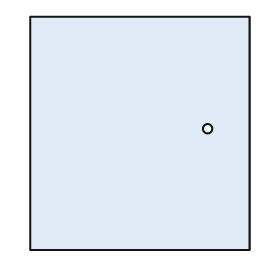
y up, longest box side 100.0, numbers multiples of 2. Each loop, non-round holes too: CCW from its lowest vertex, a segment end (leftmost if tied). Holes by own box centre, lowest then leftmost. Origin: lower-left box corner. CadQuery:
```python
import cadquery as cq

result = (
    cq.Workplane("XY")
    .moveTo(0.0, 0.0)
    .lineTo(94.0, 0.0)
    .lineTo(94.0, 100.0)
    .lineTo(0.0, 100.0)
    .close()
    .moveTo(76.0, 52.0)
    .circle(2.0)
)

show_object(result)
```